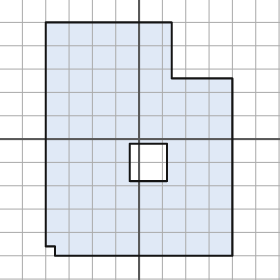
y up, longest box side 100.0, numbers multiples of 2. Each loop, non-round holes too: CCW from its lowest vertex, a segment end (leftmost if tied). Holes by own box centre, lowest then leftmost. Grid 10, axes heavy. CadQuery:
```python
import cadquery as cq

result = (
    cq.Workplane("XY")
    .moveTo(-36.0, -50.0)
    .lineTo(40.0, -50.0)
    .lineTo(40.0, 26.0)
    .lineTo(14.0, 26.0)
    .lineTo(14.0, 50.0)
    .lineTo(-40.0, 50.0)
    .lineTo(-40.0, -46.0)
    .lineTo(-36.0, -46.0)
    .close()
    .moveTo(-4.0, -18.0)
    .lineTo(12.0, -18.0)
    .lineTo(12.0, -2.0)
    .lineTo(-4.0, -2.0)
    .close()
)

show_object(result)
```